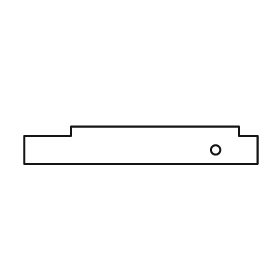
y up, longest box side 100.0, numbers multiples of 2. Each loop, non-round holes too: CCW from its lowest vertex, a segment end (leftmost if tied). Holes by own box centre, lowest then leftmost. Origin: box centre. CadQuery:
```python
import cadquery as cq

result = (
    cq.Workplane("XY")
    .moveTo(-50.0, -8.0)
    .lineTo(50.0, -8.0)
    .lineTo(50.0, 4.0)
    .lineTo(42.0, 4.0)
    .lineTo(42.0, 8.0)
    .lineTo(-30.0, 8.0)
    .lineTo(-30.0, 4.0)
    .lineTo(-50.0, 4.0)
    .close()
    .moveTo(32.0, -2.0)
    .circle(2.0)
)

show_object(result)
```